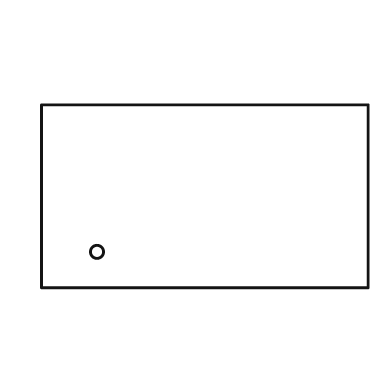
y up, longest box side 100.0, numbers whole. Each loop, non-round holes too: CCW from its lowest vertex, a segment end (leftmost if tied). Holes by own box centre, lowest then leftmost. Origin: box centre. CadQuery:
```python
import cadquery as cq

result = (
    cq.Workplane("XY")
    .moveTo(-50.0, -28.0)
    .lineTo(50.0, -28.0)
    .lineTo(50.0, 28.0)
    .lineTo(-50.0, 28.0)
    .close()
    .moveTo(-33.0, -17.0)
    .circle(2.0)
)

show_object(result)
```